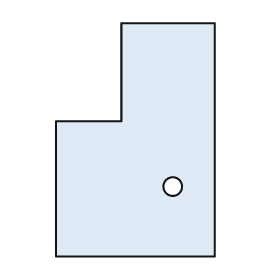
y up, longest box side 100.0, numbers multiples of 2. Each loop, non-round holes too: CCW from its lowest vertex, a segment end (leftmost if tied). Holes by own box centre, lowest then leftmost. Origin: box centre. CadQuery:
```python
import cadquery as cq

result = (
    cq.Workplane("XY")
    .moveTo(-34.0, -50.0)
    .lineTo(34.0, -50.0)
    .lineTo(34.0, 50.0)
    .lineTo(-6.0, 50.0)
    .lineTo(-6.0, 8.0)
    .lineTo(-34.0, 8.0)
    .close()
    .moveTo(16.0, -20.0)
    .circle(4.0)
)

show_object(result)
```